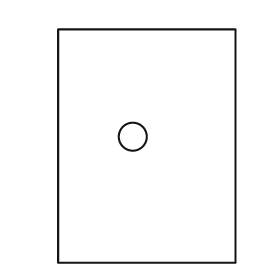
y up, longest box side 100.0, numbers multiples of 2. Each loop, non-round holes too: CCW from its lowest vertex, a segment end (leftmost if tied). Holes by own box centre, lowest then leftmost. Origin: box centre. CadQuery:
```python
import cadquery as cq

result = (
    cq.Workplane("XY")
    .moveTo(-38.0, -50.0)
    .lineTo(38.0, -50.0)
    .lineTo(38.0, 50.0)
    .lineTo(-38.0, 50.0)
    .close()
    .moveTo(-6.0, 4.0)
    .circle(6.0)
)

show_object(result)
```